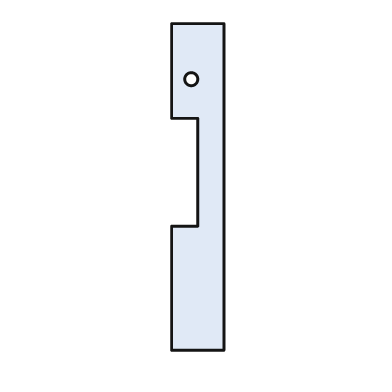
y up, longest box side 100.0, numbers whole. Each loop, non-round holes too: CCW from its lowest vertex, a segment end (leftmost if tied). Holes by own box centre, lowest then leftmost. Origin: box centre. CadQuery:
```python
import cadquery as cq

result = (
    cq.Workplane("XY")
    .moveTo(-8.0, -50.0)
    .lineTo(8.0, -50.0)
    .lineTo(8.0, 50.0)
    .lineTo(-8.0, 50.0)
    .lineTo(-8.0, 21.0)
    .lineTo(0.0, 21.0)
    .lineTo(0.0, -12.0)
    .lineTo(-8.0, -12.0)
    .close()
    .moveTo(-2.0, 33.0)
    .circle(2.0)
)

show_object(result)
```